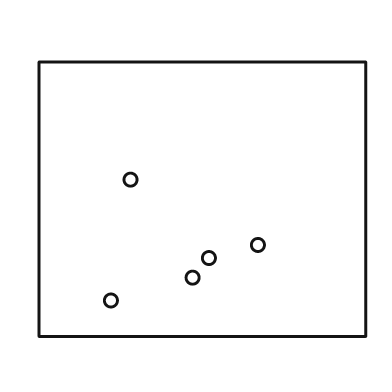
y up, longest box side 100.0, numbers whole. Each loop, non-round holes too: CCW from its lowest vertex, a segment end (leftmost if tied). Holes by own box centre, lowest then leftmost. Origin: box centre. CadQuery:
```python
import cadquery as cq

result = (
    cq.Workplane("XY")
    .moveTo(-50.0, -42.0)
    .lineTo(50.0, -42.0)
    .lineTo(50.0, 42.0)
    .lineTo(-50.0, 42.0)
    .close()
    .moveTo(-28.0, -31.0)
    .circle(2.0)
    .moveTo(-3.0, -24.0)
    .circle(2.0)
    .moveTo(2.0, -18.0)
    .circle(2.0)
    .moveTo(17.0, -14.0)
    .circle(2.0)
    .moveTo(-22.0, 6.0)
    .circle(2.0)
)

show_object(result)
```